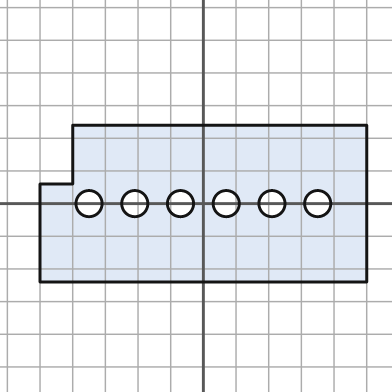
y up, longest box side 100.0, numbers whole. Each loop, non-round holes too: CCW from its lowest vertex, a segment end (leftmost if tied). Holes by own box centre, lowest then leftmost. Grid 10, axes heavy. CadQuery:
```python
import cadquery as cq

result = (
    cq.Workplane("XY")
    .moveTo(-50.0, -24.0)
    .lineTo(50.0, -24.0)
    .lineTo(50.0, 24.0)
    .lineTo(-40.0, 24.0)
    .lineTo(-40.0, 6.0)
    .lineTo(-50.0, 6.0)
    .close()
    .moveTo(-35.0, 0.0)
    .circle(4.0)
    .moveTo(-21.0, 0.0)
    .circle(4.0)
    .moveTo(-7.0, 0.0)
    .circle(4.0)
    .moveTo(7.0, 0.0)
    .circle(4.0)
    .moveTo(21.0, 0.0)
    .circle(4.0)
    .moveTo(35.0, 0.0)
    .circle(4.0)
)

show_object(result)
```